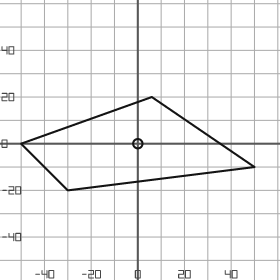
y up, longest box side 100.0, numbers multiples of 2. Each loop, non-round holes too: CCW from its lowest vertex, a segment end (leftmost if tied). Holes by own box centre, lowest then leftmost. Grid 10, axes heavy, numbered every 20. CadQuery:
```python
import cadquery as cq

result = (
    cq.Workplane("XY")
    .moveTo(-30.0, -20.0)
    .lineTo(50.0, -10.0)
    .lineTo(6.0, 20.0)
    .lineTo(-50.0, 0.0)
    .close()
    .moveTo(0.0, 0.0)
    .circle(2.0)
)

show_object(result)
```